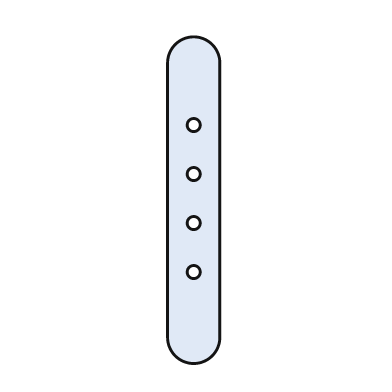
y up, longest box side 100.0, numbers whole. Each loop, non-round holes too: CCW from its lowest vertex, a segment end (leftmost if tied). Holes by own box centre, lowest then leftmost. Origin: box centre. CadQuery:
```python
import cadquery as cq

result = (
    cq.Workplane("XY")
    .moveTo(-8.0, -42.0)
    .threePointArc((0.0, -50.0), (8.0, -42.0))
    .lineTo(8.0, 42.0)
    .threePointArc((0.0, 50.0), (-8.0, 42.0))
    .close()
    .moveTo(0.0, -22.0)
    .circle(2.0)
    .moveTo(0.0, -7.0)
    .circle(2.0)
    .moveTo(0.0, 8.0)
    .circle(2.0)
    .moveTo(0.0, 23.0)
    .circle(2.0)
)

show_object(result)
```